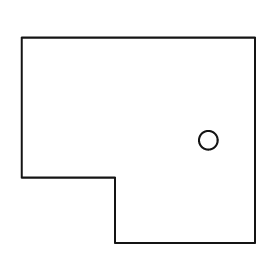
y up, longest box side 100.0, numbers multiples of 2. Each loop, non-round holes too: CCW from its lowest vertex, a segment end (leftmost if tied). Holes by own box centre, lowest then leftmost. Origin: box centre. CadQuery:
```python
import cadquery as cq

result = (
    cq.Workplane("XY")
    .moveTo(-10.0, -44.0)
    .lineTo(50.0, -44.0)
    .lineTo(50.0, 44.0)
    .lineTo(-50.0, 44.0)
    .lineTo(-50.0, -16.0)
    .lineTo(-10.0, -16.0)
    .close()
    .moveTo(30.0, 0.0)
    .circle(4.0)
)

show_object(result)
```